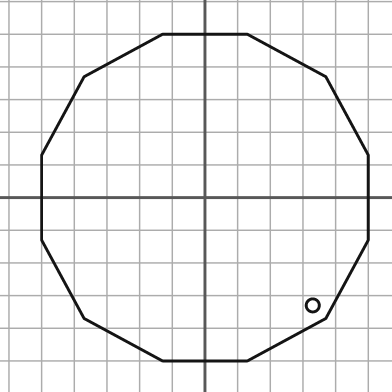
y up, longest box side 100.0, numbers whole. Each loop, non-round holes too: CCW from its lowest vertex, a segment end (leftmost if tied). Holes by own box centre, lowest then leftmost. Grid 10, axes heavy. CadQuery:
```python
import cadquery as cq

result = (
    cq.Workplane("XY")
    .moveTo(-13.0, -50.0)
    .lineTo(13.0, -50.0)
    .lineTo(37.0, -37.0)
    .lineTo(50.0, -13.0)
    .lineTo(50.0, 13.0)
    .lineTo(37.0, 37.0)
    .lineTo(13.0, 50.0)
    .lineTo(-13.0, 50.0)
    .lineTo(-37.0, 37.0)
    .lineTo(-50.0, 13.0)
    .lineTo(-50.0, -13.0)
    .lineTo(-37.0, -37.0)
    .close()
    .moveTo(33.0, -33.0)
    .circle(2.0)
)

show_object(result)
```